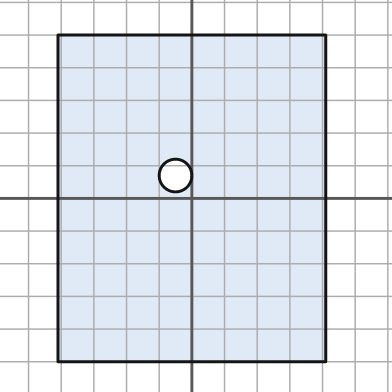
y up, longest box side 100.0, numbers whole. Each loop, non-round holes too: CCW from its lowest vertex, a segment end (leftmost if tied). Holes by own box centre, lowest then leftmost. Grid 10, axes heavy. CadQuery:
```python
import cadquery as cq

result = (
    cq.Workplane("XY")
    .moveTo(-41.0, -50.0)
    .lineTo(41.0, -50.0)
    .lineTo(41.0, 50.0)
    .lineTo(-41.0, 50.0)
    .close()
    .moveTo(-5.0, 7.0)
    .circle(5.0)
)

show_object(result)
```